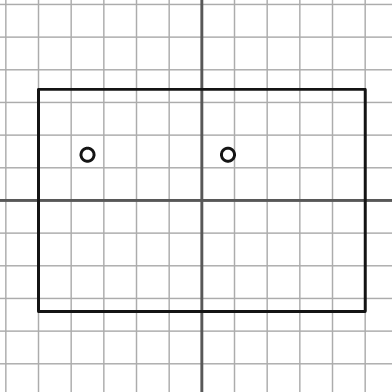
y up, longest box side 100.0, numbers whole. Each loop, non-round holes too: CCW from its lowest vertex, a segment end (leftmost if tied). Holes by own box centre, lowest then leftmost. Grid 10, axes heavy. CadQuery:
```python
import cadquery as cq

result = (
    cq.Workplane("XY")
    .moveTo(-50.0, -34.0)
    .lineTo(50.0, -34.0)
    .lineTo(50.0, 34.0)
    .lineTo(-50.0, 34.0)
    .close()
    .moveTo(-35.0, 14.0)
    .circle(2.0)
    .moveTo(8.0, 14.0)
    .circle(2.0)
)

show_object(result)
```